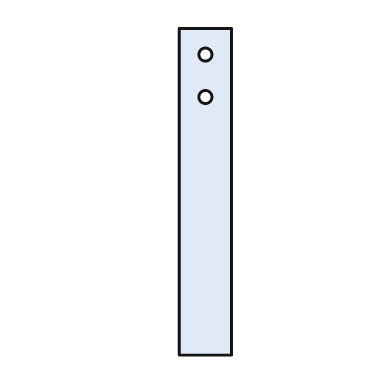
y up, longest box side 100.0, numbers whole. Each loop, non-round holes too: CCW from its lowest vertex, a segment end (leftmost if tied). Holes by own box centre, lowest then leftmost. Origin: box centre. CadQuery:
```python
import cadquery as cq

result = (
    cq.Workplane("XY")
    .moveTo(-8.0, -50.0)
    .lineTo(8.0, -50.0)
    .lineTo(8.0, 50.0)
    .lineTo(-8.0, 50.0)
    .close()
    .moveTo(0.0, 29.0)
    .circle(2.0)
    .moveTo(0.0, 42.0)
    .circle(2.0)
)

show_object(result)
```